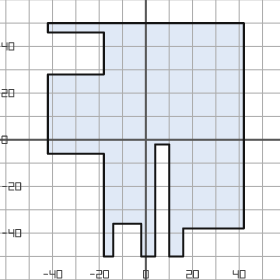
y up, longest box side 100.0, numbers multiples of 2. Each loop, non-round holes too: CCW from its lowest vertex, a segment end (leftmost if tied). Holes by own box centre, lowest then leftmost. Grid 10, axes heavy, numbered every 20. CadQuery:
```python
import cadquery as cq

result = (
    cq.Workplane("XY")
    .moveTo(-18.0, -50.0)
    .lineTo(-14.0, -50.0)
    .lineTo(-14.0, -36.0)
    .lineTo(-2.0, -36.0)
    .lineTo(-2.0, -50.0)
    .lineTo(4.0, -50.0)
    .lineTo(4.0, -2.0)
    .lineTo(10.0, -2.0)
    .lineTo(10.0, -50.0)
    .lineTo(16.0, -50.0)
    .lineTo(16.0, -38.0)
    .lineTo(42.0, -38.0)
    .lineTo(42.0, 50.0)
    .lineTo(-42.0, 50.0)
    .lineTo(-42.0, 46.0)
    .lineTo(-18.0, 46.0)
    .lineTo(-18.0, 28.0)
    .lineTo(-42.0, 28.0)
    .lineTo(-42.0, -6.0)
    .lineTo(-18.0, -6.0)
    .close()
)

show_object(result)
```